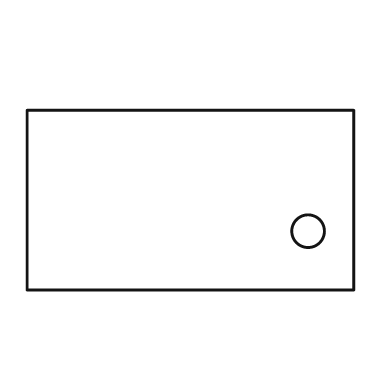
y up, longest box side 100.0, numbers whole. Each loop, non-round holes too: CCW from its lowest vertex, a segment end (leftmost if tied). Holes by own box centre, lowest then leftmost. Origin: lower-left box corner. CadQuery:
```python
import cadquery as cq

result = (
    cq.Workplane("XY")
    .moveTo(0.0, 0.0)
    .lineTo(100.0, 0.0)
    .lineTo(100.0, 55.0)
    .lineTo(0.0, 55.0)
    .close()
    .moveTo(86.0, 18.0)
    .circle(5.0)
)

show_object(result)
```